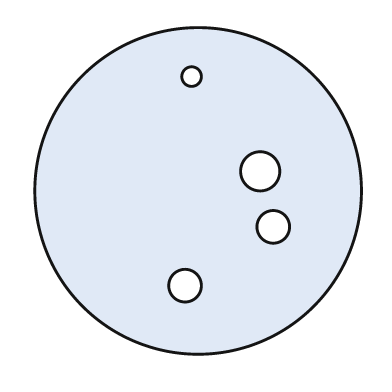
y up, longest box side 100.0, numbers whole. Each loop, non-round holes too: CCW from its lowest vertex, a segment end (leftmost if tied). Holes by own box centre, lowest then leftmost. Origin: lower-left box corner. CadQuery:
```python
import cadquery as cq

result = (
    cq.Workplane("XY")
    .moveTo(50.0, 50.0)
    .circle(50.0)
    .moveTo(46.0, 21.0)
    .circle(5.0)
    .moveTo(73.0, 39.0)
    .circle(5.0)
    .moveTo(69.0, 56.0)
    .circle(6.0)
    .moveTo(48.0, 85.0)
    .circle(3.0)
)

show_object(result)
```